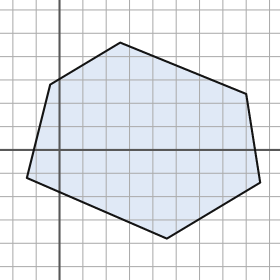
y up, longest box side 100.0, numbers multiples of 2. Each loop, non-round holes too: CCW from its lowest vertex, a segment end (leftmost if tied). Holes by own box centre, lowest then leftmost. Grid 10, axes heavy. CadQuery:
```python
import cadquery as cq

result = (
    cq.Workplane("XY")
    .moveTo(46.0, -38.0)
    .lineTo(86.0, -14.0)
    .lineTo(80.0, 24.0)
    .lineTo(26.0, 46.0)
    .lineTo(-4.0, 28.0)
    .lineTo(-14.0, -12.0)
    .close()
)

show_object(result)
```